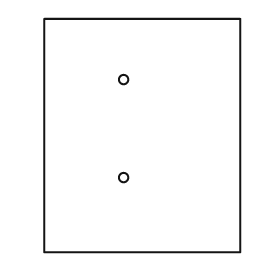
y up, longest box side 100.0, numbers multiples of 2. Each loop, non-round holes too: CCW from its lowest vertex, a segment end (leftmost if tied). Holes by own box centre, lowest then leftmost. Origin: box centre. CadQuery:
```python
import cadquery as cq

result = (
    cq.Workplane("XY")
    .moveTo(-42.0, -50.0)
    .lineTo(42.0, -50.0)
    .lineTo(42.0, 50.0)
    .lineTo(-42.0, 50.0)
    .close()
    .moveTo(-8.0, -18.0)
    .circle(2.0)
    .moveTo(-8.0, 24.0)
    .circle(2.0)
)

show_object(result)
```